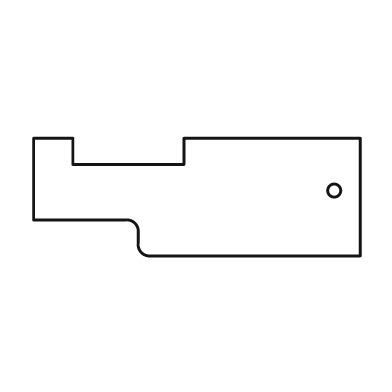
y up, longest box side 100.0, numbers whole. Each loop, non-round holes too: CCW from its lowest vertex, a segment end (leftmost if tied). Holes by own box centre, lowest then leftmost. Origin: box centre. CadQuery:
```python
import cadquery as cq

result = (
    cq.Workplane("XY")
    .moveTo(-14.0, -18.0)
    .lineTo(50.0, -18.0)
    .lineTo(50.0, 18.0)
    .lineTo(-4.0, 18.0)
    .lineTo(-4.0, 10.0)
    .lineTo(-38.0, 10.0)
    .lineTo(-38.0, 18.0)
    .lineTo(-50.0, 18.0)
    .lineTo(-50.0, -7.0)
    .lineTo(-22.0, -7.0)
    .threePointArc((-19.0, -8.0), (-18.0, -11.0))
    .lineTo(-18.0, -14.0)
    .threePointArc((-17.0, -17.0), (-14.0, -18.0))
    .close()
    .moveTo(42.0, 2.0)
    .circle(2.0)
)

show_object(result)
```